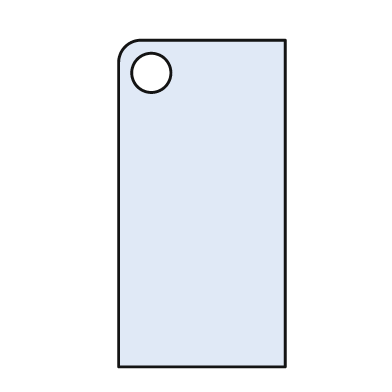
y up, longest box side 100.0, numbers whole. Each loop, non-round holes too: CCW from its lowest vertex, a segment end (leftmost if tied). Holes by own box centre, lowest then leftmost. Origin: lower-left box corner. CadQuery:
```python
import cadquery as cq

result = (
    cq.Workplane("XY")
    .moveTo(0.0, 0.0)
    .lineTo(51.0, 0.0)
    .lineTo(51.0, 100.0)
    .lineTo(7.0, 100.0)
    .threePointArc((2.0, 98.0), (0.0, 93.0))
    .close()
    .moveTo(10.0, 90.0)
    .circle(6.0)
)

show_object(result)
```